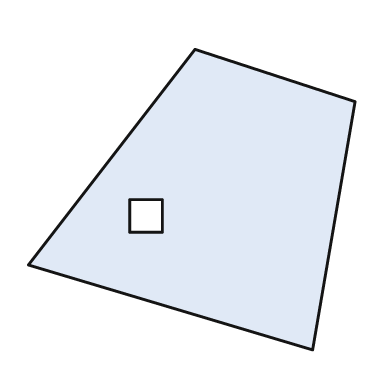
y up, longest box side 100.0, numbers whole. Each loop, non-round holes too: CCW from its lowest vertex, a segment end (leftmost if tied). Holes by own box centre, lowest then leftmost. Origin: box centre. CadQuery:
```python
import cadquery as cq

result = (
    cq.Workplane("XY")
    .moveTo(37.0, -46.0)
    .lineTo(50.0, 30.0)
    .lineTo(1.0, 46.0)
    .lineTo(-50.0, -20.0)
    .close()
    .moveTo(-19.0, -10.0)
    .lineTo(-9.0, -10.0)
    .lineTo(-9.0, 0.0)
    .lineTo(-19.0, 0.0)
    .close()
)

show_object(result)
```